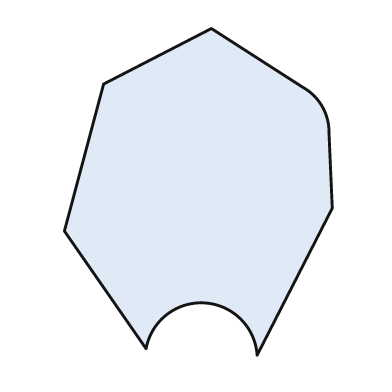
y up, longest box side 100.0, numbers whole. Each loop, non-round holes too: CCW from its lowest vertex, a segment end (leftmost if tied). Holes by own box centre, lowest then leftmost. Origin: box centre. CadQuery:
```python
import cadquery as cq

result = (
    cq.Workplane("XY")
    .moveTo(18.0, -50.0)
    .lineTo(41.0, -5.0)
    .lineTo(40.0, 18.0)
    .threePointArc((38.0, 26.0), (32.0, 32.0))
    .lineTo(4.0, 50.0)
    .lineTo(-29.0, 33.0)
    .lineTo(-41.0, -12.0)
    .lineTo(-16.0, -48.0)
    .threePointArc((2.0, -34.0), (18.0, -50.0))
    .close()
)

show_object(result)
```